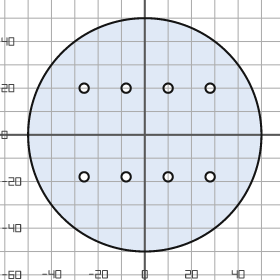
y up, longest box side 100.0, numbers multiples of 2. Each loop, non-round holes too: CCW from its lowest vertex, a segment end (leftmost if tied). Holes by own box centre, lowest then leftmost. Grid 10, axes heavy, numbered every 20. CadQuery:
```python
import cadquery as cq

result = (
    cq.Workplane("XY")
    .moveTo(0.0, 0.0)
    .circle(50.0)
    .moveTo(-26.0, -18.0)
    .circle(2.0)
    .moveTo(-8.0, -18.0)
    .circle(2.0)
    .moveTo(10.0, -18.0)
    .circle(2.0)
    .moveTo(28.0, -18.0)
    .circle(2.0)
    .moveTo(-26.0, 20.0)
    .circle(2.0)
    .moveTo(-8.0, 20.0)
    .circle(2.0)
    .moveTo(10.0, 20.0)
    .circle(2.0)
    .moveTo(28.0, 20.0)
    .circle(2.0)
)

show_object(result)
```